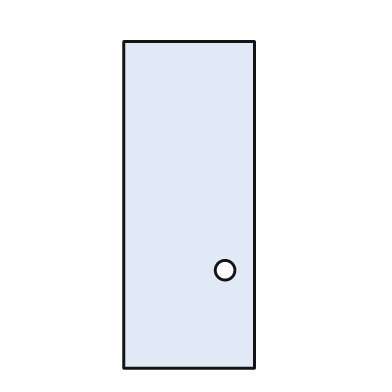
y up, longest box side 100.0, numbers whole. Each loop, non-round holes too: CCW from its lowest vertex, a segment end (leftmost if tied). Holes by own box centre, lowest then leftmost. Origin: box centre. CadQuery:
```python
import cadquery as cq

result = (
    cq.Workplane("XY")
    .moveTo(-20.0, -50.0)
    .lineTo(20.0, -50.0)
    .lineTo(20.0, 50.0)
    .lineTo(-20.0, 50.0)
    .close()
    .moveTo(11.0, -20.0)
    .circle(3.0)
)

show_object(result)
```